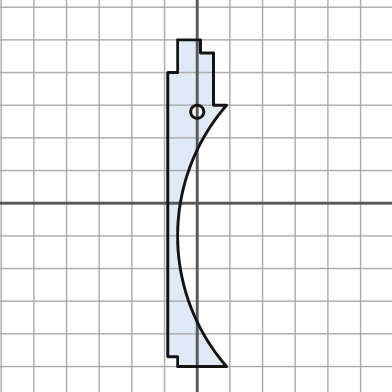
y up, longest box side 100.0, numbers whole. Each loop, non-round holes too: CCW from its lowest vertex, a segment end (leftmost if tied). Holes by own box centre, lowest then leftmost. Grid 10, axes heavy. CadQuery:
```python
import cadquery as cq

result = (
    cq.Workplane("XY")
    .moveTo(-6.0, -50.0)
    .lineTo(9.0, -50.0)
    .threePointArc((-6.0, -10.0), (9.0, 30.0))
    .lineTo(5.0, 30.0)
    .lineTo(5.0, 46.0)
    .lineTo(1.0, 46.0)
    .lineTo(1.0, 50.0)
    .lineTo(-6.0, 50.0)
    .lineTo(-6.0, 40.0)
    .lineTo(-9.0, 40.0)
    .lineTo(-9.0, -47.0)
    .lineTo(-6.0, -47.0)
    .close()
    .moveTo(0.0, 28.0)
    .circle(2.0)
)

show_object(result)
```